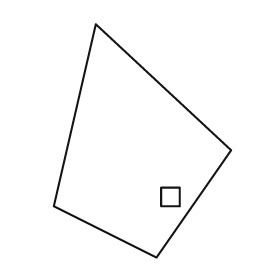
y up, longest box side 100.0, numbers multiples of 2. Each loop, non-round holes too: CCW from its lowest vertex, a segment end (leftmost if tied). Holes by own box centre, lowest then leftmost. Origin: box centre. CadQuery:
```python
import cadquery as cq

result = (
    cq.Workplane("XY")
    .moveTo(6.0, -50.0)
    .lineTo(38.0, -4.0)
    .lineTo(-20.0, 50.0)
    .lineTo(-38.0, -28.0)
    .close()
    .moveTo(8.0, -28.0)
    .lineTo(16.0, -28.0)
    .lineTo(16.0, -20.0)
    .lineTo(8.0, -20.0)
    .close()
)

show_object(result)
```